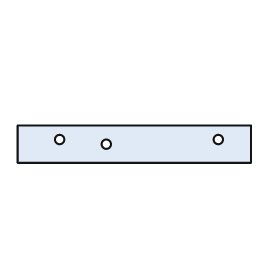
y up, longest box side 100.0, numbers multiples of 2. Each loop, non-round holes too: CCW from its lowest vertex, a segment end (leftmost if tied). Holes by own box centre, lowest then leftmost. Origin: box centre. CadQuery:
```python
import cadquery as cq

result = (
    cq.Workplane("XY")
    .moveTo(-50.0, -8.0)
    .lineTo(50.0, -8.0)
    .lineTo(50.0, 8.0)
    .lineTo(-50.0, 8.0)
    .close()
    .moveTo(-12.0, 0.0)
    .circle(2.0)
    .moveTo(-32.0, 2.0)
    .circle(2.0)
    .moveTo(36.0, 2.0)
    .circle(2.0)
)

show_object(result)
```